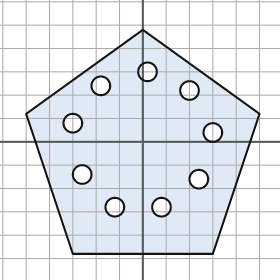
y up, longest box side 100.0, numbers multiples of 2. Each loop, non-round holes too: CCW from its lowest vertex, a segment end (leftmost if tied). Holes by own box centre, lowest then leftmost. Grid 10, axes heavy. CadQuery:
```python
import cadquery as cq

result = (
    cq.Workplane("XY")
    .moveTo(-30.0, -48.0)
    .lineTo(30.0, -48.0)
    .lineTo(50.0, 12.0)
    .lineTo(0.0, 48.0)
    .lineTo(-50.0, 12.0)
    .close()
    .moveTo(-12.0, -28.0)
    .circle(4.0)
    .moveTo(8.0, -28.0)
    .circle(4.0)
    .moveTo(24.0, -16.0)
    .circle(4.0)
    .moveTo(-26.0, -14.0)
    .circle(4.0)
    .moveTo(30.0, 4.0)
    .circle(4.0)
    .moveTo(-30.0, 8.0)
    .circle(4.0)
    .moveTo(20.0, 22.0)
    .circle(4.0)
    .moveTo(-18.0, 24.0)
    .circle(4.0)
    .moveTo(2.0, 30.0)
    .circle(4.0)
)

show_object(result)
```